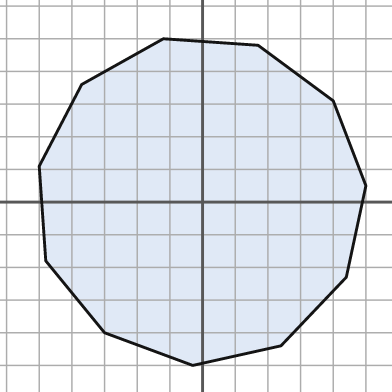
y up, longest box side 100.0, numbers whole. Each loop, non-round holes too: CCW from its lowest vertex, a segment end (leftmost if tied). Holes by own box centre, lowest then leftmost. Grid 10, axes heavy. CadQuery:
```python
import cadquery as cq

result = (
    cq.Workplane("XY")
    .moveTo(-3.0, -50.0)
    .lineTo(24.0, -44.0)
    .lineTo(44.0, -23.0)
    .lineTo(50.0, 5.0)
    .lineTo(40.0, 31.0)
    .lineTo(17.0, 48.0)
    .lineTo(-12.0, 50.0)
    .lineTo(-37.0, 36.0)
    .lineTo(-50.0, 11.0)
    .lineTo(-48.0, -18.0)
    .lineTo(-30.0, -40.0)
    .close()
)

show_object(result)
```